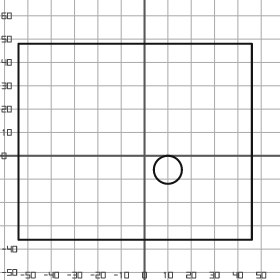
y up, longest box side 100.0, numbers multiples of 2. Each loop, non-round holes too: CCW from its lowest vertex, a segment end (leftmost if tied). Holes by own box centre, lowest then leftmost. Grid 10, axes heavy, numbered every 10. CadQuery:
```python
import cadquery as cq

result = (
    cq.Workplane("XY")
    .moveTo(-54.0, -36.0)
    .lineTo(46.0, -36.0)
    .lineTo(46.0, 48.0)
    .lineTo(-54.0, 48.0)
    .close()
    .moveTo(10.0, -6.0)
    .circle(6.0)
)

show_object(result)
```